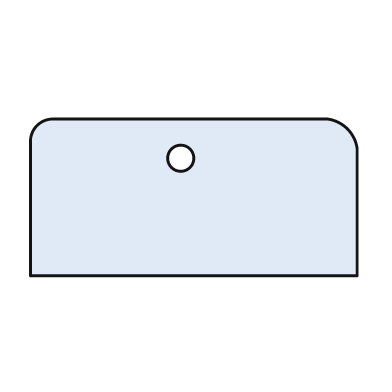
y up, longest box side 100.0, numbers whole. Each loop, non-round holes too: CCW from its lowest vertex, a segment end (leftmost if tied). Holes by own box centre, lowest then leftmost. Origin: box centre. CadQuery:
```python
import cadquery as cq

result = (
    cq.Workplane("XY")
    .moveTo(-50.0, -24.0)
    .lineTo(50.0, -24.0)
    .lineTo(50.0, 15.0)
    .threePointArc((47.0, 21.0), (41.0, 24.0))
    .lineTo(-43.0, 24.0)
    .threePointArc((-48.0, 22.0), (-50.0, 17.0))
    .close()
    .moveTo(-4.0, 12.0)
    .circle(4.0)
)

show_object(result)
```